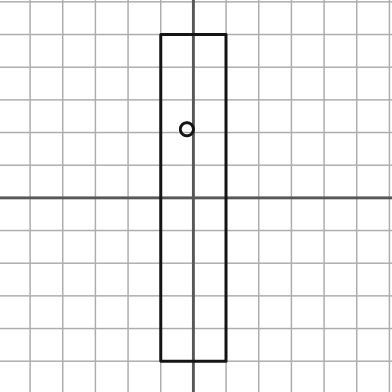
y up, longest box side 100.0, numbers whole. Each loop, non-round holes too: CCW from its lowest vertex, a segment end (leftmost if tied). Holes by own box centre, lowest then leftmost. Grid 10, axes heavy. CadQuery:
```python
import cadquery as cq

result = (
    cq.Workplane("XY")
    .moveTo(-10.0, -50.0)
    .lineTo(10.0, -50.0)
    .lineTo(10.0, 50.0)
    .lineTo(-10.0, 50.0)
    .close()
    .moveTo(-2.0, 21.0)
    .circle(2.0)
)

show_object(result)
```